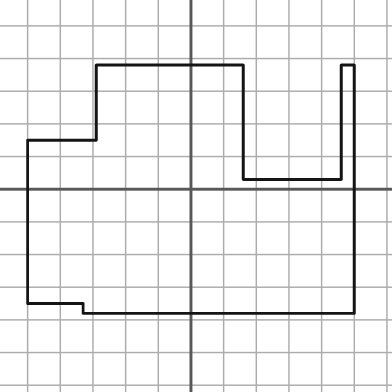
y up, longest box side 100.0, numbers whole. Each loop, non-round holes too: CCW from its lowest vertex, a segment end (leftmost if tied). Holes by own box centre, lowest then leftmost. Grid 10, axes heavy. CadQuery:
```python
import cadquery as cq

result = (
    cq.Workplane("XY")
    .moveTo(-33.0, -38.0)
    .lineTo(50.0, -38.0)
    .lineTo(50.0, 38.0)
    .lineTo(46.0, 38.0)
    .lineTo(46.0, 3.0)
    .lineTo(16.0, 3.0)
    .lineTo(16.0, 38.0)
    .lineTo(-29.0, 38.0)
    .lineTo(-29.0, 15.0)
    .lineTo(-50.0, 15.0)
    .lineTo(-50.0, -35.0)
    .lineTo(-33.0, -35.0)
    .close()
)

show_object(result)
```